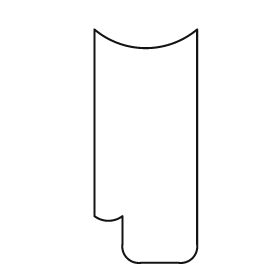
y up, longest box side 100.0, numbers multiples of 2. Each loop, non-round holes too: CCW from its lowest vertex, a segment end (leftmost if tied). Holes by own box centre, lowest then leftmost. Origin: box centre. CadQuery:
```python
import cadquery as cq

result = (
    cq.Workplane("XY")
    .moveTo(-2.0, -50.0)
    .lineTo(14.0, -50.0)
    .threePointArc((20.0, -48.0), (22.0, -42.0))
    .lineTo(22.0, 50.0)
    .threePointArc((0.0, 42.0), (-22.0, 50.0))
    .lineTo(-22.0, -30.0)
    .threePointArc((-16.0, -32.0), (-10.0, -30.0))
    .lineTo(-10.0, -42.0)
    .threePointArc((-8.0, -48.0), (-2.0, -50.0))
    .close()
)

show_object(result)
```